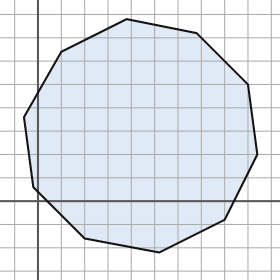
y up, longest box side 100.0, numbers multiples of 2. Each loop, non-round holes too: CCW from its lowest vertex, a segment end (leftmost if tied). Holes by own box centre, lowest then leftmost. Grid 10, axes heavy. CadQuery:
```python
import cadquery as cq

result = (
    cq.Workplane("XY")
    .moveTo(52.0, -22.0)
    .lineTo(80.0, -8.0)
    .lineTo(94.0, 20.0)
    .lineTo(90.0, 50.0)
    .lineTo(68.0, 72.0)
    .lineTo(38.0, 78.0)
    .lineTo(10.0, 64.0)
    .lineTo(-6.0, 36.0)
    .lineTo(-2.0, 6.0)
    .lineTo(20.0, -16.0)
    .close()
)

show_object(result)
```